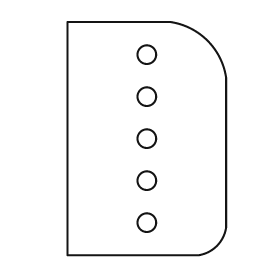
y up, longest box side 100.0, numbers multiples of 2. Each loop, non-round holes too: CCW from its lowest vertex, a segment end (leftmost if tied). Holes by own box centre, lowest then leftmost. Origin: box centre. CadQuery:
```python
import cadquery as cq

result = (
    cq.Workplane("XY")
    .moveTo(-34.0, -50.0)
    .lineTo(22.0, -50.0)
    .threePointArc((30.0, -46.0), (34.0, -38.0))
    .lineTo(34.0, 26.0)
    .threePointArc((26.0, 42.0), (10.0, 50.0))
    .lineTo(-34.0, 50.0)
    .close()
    .moveTo(0.0, -36.0)
    .circle(4.0)
    .moveTo(0.0, -18.0)
    .circle(4.0)
    .moveTo(0.0, 0.0)
    .circle(4.0)
    .moveTo(0.0, 18.0)
    .circle(4.0)
    .moveTo(0.0, 36.0)
    .circle(4.0)
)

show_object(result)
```